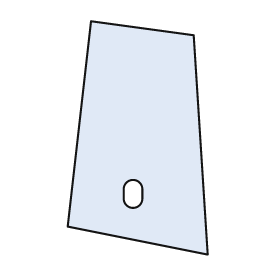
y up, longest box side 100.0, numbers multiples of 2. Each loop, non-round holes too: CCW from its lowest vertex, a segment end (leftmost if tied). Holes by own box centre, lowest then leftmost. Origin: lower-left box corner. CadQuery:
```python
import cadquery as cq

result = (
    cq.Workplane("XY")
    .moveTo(60.0, 0.0)
    .lineTo(54.0, 94.0)
    .lineTo(10.0, 100.0)
    .lineTo(0.0, 12.0)
    .close()
    .moveTo(24.0, 24.0)
    .threePointArc((28.0, 20.0), (32.0, 24.0))
    .lineTo(32.0, 28.0)
    .threePointArc((28.0, 32.0), (24.0, 28.0))
    .close()
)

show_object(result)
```